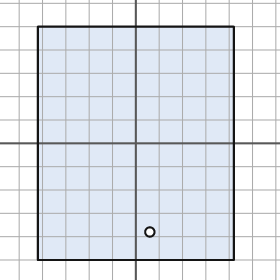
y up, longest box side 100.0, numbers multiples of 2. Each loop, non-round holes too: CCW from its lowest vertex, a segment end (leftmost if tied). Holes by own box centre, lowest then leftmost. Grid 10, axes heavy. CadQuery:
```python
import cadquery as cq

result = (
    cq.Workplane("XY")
    .moveTo(-42.0, -50.0)
    .lineTo(42.0, -50.0)
    .lineTo(42.0, 50.0)
    .lineTo(-42.0, 50.0)
    .close()
    .moveTo(6.0, -38.0)
    .circle(2.0)
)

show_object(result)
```